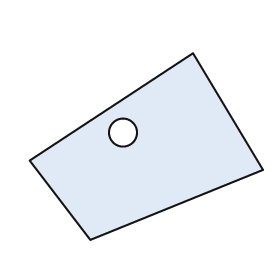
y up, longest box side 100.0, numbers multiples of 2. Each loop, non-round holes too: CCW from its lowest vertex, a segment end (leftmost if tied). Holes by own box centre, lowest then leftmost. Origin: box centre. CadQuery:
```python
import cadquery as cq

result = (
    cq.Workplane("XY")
    .moveTo(-24.0, -40.0)
    .lineTo(50.0, -10.0)
    .lineTo(20.0, 40.0)
    .lineTo(-50.0, -6.0)
    .close()
    .moveTo(-10.0, 6.0)
    .circle(6.0)
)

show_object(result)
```